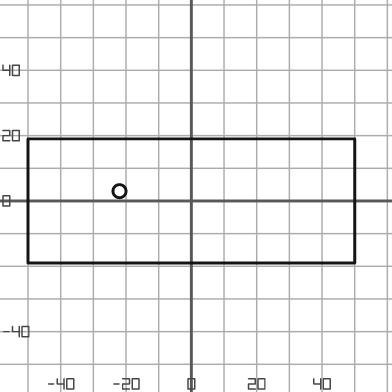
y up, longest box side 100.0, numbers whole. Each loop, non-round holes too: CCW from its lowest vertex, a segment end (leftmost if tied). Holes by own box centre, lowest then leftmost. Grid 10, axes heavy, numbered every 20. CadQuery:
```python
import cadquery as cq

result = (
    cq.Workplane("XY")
    .moveTo(-50.0, -19.0)
    .lineTo(50.0, -19.0)
    .lineTo(50.0, 19.0)
    .lineTo(-50.0, 19.0)
    .close()
    .moveTo(-22.0, 3.0)
    .circle(2.0)
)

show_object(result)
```